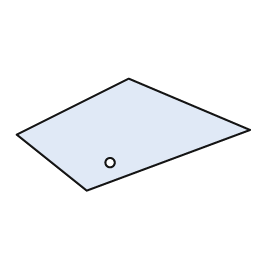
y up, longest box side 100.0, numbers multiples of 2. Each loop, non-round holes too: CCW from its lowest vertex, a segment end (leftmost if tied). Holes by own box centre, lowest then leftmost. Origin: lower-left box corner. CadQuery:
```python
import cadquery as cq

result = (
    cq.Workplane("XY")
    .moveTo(30.0, 0.0)
    .lineTo(100.0, 26.0)
    .lineTo(48.0, 48.0)
    .lineTo(0.0, 24.0)
    .close()
    .moveTo(40.0, 12.0)
    .circle(2.0)
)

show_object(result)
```